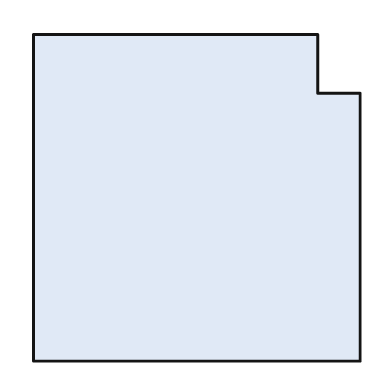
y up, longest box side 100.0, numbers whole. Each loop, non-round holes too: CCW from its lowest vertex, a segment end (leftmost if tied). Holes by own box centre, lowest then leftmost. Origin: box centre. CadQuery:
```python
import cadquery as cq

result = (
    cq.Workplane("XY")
    .moveTo(-50.0, -50.0)
    .lineTo(50.0, -50.0)
    .lineTo(50.0, 32.0)
    .lineTo(37.0, 32.0)
    .lineTo(37.0, 50.0)
    .lineTo(-50.0, 50.0)
    .close()
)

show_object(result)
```